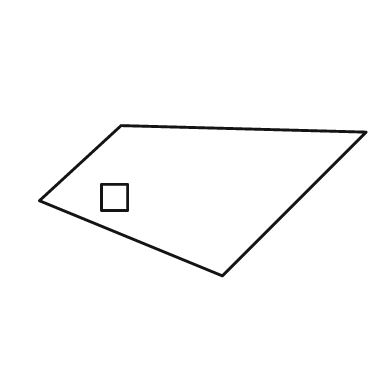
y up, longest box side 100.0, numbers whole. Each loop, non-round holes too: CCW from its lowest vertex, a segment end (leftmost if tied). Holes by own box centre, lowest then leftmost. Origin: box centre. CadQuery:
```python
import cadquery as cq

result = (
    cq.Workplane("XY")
    .moveTo(6.0, -23.0)
    .lineTo(50.0, 21.0)
    .lineTo(-25.0, 23.0)
    .lineTo(-50.0, 0.0)
    .close()
    .moveTo(-31.0, -3.0)
    .lineTo(-23.0, -3.0)
    .lineTo(-23.0, 5.0)
    .lineTo(-31.0, 5.0)
    .close()
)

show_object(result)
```